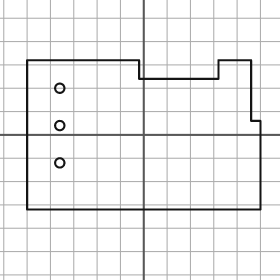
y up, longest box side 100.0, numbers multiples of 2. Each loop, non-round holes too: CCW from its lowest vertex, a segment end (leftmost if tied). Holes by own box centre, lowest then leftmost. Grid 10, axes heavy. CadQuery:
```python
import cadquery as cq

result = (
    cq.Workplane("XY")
    .moveTo(-50.0, -32.0)
    .lineTo(50.0, -32.0)
    .lineTo(50.0, 6.0)
    .lineTo(46.0, 6.0)
    .lineTo(46.0, 32.0)
    .lineTo(32.0, 32.0)
    .lineTo(32.0, 24.0)
    .lineTo(-2.0, 24.0)
    .lineTo(-2.0, 32.0)
    .lineTo(-50.0, 32.0)
    .close()
    .moveTo(-36.0, -12.0)
    .circle(2.0)
    .moveTo(-36.0, 4.0)
    .circle(2.0)
    .moveTo(-36.0, 20.0)
    .circle(2.0)
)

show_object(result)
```